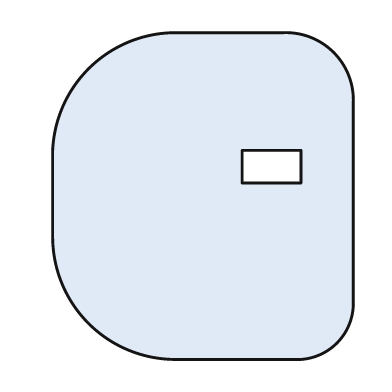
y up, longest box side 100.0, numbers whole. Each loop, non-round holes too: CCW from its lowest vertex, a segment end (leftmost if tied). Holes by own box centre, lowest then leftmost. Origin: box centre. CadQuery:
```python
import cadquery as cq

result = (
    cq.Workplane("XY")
    .moveTo(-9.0, -50.0)
    .lineTo(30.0, -50.0)
    .threePointArc((41.0, -45.0), (46.0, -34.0))
    .lineTo(46.0, 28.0)
    .threePointArc((40.0, 44.0), (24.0, 50.0))
    .lineTo(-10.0, 50.0)
    .threePointArc((-35.0, 39.0), (-46.0, 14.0))
    .lineTo(-46.0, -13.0)
    .threePointArc((-35.0, -39.0), (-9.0, -50.0))
    .close()
    .moveTo(12.0, 4.0)
    .lineTo(30.0, 4.0)
    .lineTo(30.0, 14.0)
    .lineTo(12.0, 14.0)
    .close()
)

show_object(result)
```